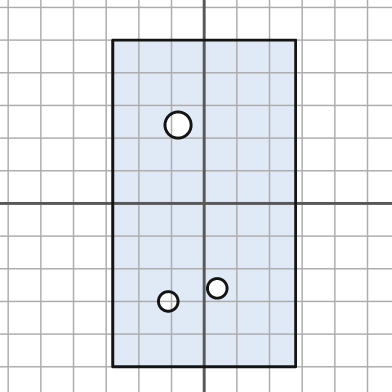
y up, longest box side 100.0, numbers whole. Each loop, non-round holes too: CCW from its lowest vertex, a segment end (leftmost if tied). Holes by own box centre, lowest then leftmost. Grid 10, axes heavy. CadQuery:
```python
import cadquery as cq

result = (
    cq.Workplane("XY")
    .moveTo(-28.0, -50.0)
    .lineTo(28.0, -50.0)
    .lineTo(28.0, 50.0)
    .lineTo(-28.0, 50.0)
    .close()
    .moveTo(-11.0, -30.0)
    .circle(3.0)
    .moveTo(4.0, -26.0)
    .circle(3.0)
    .moveTo(-8.0, 24.0)
    .circle(4.0)
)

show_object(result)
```